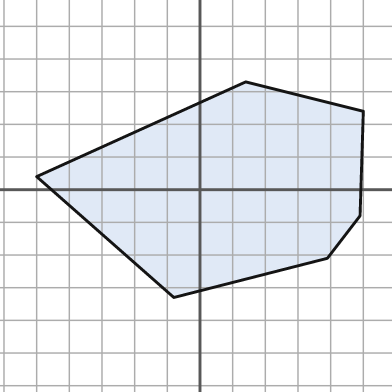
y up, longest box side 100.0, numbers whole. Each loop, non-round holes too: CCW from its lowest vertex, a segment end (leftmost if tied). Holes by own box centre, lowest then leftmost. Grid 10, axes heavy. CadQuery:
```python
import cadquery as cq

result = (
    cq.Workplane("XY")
    .moveTo(-8.0, -33.0)
    .lineTo(39.0, -21.0)
    .lineTo(49.0, -8.0)
    .lineTo(50.0, 24.0)
    .lineTo(14.0, 33.0)
    .lineTo(-50.0, 4.0)
    .close()
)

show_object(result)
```